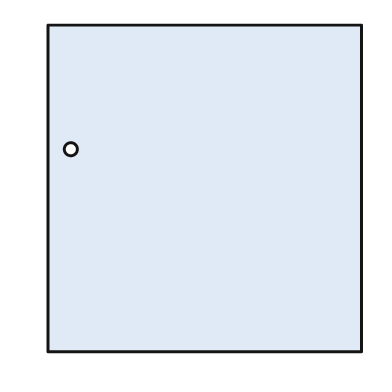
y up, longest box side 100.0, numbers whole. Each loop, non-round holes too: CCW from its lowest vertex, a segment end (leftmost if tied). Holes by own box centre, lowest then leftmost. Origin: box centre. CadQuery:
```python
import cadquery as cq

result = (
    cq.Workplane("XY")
    .moveTo(-48.0, -50.0)
    .lineTo(48.0, -50.0)
    .lineTo(48.0, 50.0)
    .lineTo(-48.0, 50.0)
    .close()
    .moveTo(-41.0, 12.0)
    .circle(2.0)
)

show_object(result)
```